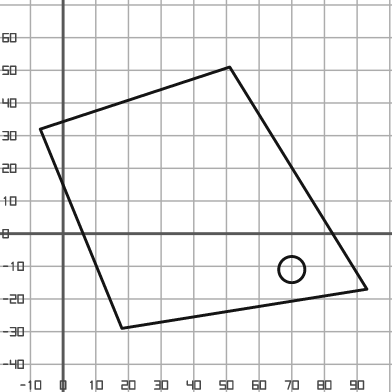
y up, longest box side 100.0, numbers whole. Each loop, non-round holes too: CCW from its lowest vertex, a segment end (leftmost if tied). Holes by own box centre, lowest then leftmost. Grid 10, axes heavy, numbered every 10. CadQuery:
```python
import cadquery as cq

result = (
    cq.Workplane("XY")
    .moveTo(18.0, -29.0)
    .lineTo(93.0, -17.0)
    .lineTo(51.0, 51.0)
    .lineTo(-7.0, 32.0)
    .close()
    .moveTo(70.0, -11.0)
    .circle(4.0)
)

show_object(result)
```